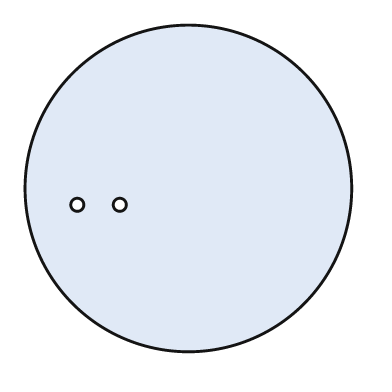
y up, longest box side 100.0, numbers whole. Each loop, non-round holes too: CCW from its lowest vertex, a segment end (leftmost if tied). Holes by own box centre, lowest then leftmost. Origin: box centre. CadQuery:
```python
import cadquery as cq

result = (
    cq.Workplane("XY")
    .moveTo(0.0, 0.0)
    .circle(50.0)
    .moveTo(-34.0, -5.0)
    .circle(2.0)
    .moveTo(-21.0, -5.0)
    .circle(2.0)
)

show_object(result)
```